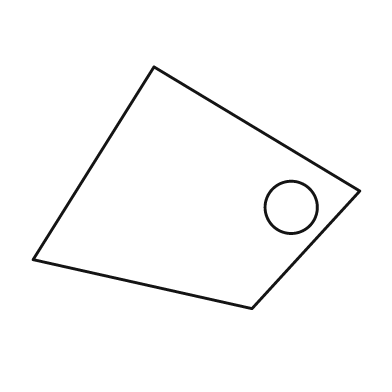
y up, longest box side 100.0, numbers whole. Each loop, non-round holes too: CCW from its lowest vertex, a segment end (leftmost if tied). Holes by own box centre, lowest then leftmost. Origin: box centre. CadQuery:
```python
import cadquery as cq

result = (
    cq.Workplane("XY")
    .moveTo(17.0, -37.0)
    .lineTo(50.0, -1.0)
    .lineTo(-13.0, 37.0)
    .lineTo(-50.0, -22.0)
    .close()
    .moveTo(29.0, -6.0)
    .circle(8.0)
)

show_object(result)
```